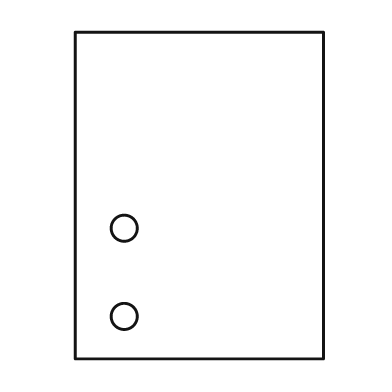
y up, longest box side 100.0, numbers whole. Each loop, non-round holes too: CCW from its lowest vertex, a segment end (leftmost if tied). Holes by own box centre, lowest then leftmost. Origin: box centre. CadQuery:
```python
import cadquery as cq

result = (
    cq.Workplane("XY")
    .moveTo(-38.0, -50.0)
    .lineTo(38.0, -50.0)
    .lineTo(38.0, 50.0)
    .lineTo(-38.0, 50.0)
    .close()
    .moveTo(-23.0, -37.0)
    .circle(4.0)
    .moveTo(-23.0, -10.0)
    .circle(4.0)
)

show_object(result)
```